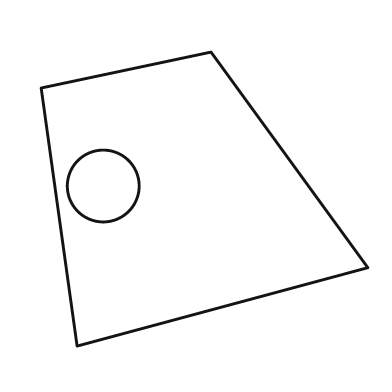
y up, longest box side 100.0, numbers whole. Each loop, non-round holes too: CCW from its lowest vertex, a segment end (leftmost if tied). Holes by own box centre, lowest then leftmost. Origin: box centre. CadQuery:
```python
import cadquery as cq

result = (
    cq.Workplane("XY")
    .moveTo(-39.0, -45.0)
    .lineTo(50.0, -21.0)
    .lineTo(2.0, 45.0)
    .lineTo(-50.0, 34.0)
    .close()
    .moveTo(-31.0, 4.0)
    .circle(11.0)
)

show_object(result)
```